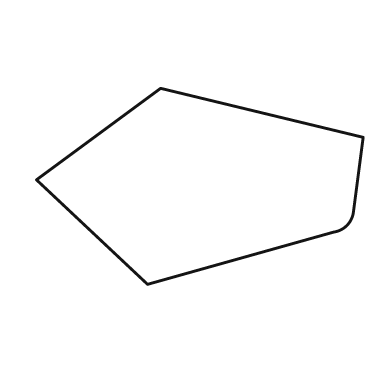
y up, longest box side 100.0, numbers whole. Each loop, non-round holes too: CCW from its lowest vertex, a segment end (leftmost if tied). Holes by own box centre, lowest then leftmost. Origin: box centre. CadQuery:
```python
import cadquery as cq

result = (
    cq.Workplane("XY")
    .moveTo(-16.0, -30.0)
    .lineTo(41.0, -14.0)
    .threePointArc((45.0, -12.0), (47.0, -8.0))
    .lineTo(50.0, 15.0)
    .lineTo(-12.0, 30.0)
    .lineTo(-50.0, 2.0)
    .close()
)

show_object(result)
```